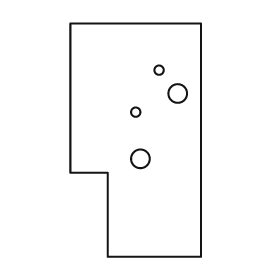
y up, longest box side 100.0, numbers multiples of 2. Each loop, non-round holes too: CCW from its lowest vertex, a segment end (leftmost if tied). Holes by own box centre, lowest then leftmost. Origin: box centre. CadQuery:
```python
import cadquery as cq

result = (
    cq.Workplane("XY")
    .moveTo(-12.0, -50.0)
    .lineTo(28.0, -50.0)
    .lineTo(28.0, 50.0)
    .lineTo(-28.0, 50.0)
    .lineTo(-28.0, -14.0)
    .lineTo(-12.0, -14.0)
    .close()
    .moveTo(2.0, -8.0)
    .circle(4.0)
    .moveTo(0.0, 12.0)
    .circle(2.0)
    .moveTo(18.0, 20.0)
    .circle(4.0)
    .moveTo(10.0, 30.0)
    .circle(2.0)
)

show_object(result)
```